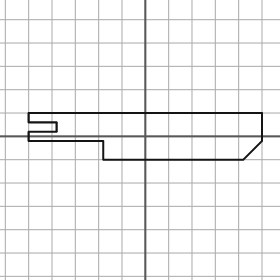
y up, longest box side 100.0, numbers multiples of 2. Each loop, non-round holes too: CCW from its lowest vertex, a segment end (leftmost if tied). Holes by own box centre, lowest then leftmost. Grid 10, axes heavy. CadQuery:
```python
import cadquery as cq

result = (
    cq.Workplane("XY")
    .moveTo(-18.0, -10.0)
    .lineTo(42.0, -10.0)
    .lineTo(50.0, -2.0)
    .lineTo(50.0, 10.0)
    .lineTo(-50.0, 10.0)
    .lineTo(-50.0, 6.0)
    .lineTo(-38.0, 6.0)
    .lineTo(-38.0, 2.0)
    .lineTo(-50.0, 2.0)
    .lineTo(-50.0, -2.0)
    .lineTo(-18.0, -2.0)
    .close()
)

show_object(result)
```